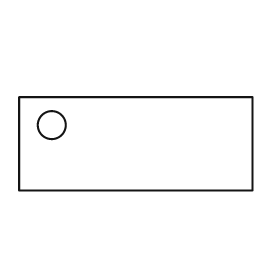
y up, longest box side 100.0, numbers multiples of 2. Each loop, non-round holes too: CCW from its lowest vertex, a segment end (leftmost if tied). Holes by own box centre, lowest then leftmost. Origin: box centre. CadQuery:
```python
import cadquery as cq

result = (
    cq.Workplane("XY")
    .moveTo(-50.0, -20.0)
    .lineTo(50.0, -20.0)
    .lineTo(50.0, 20.0)
    .lineTo(-50.0, 20.0)
    .close()
    .moveTo(-36.0, 8.0)
    .circle(6.0)
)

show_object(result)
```